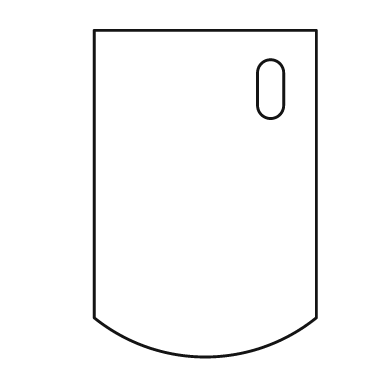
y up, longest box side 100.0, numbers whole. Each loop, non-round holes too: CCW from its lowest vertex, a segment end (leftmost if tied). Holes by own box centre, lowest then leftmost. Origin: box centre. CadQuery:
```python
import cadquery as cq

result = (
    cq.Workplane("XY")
    .moveTo(-34.0, -38.0)
    .threePointArc((0.0, -50.0), (34.0, -38.0))
    .lineTo(34.0, 50.0)
    .lineTo(-34.0, 50.0)
    .close()
    .moveTo(16.0, 27.0)
    .threePointArc((20.0, 23.0), (24.0, 27.0))
    .lineTo(24.0, 37.0)
    .threePointArc((20.0, 41.0), (16.0, 37.0))
    .close()
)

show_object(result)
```